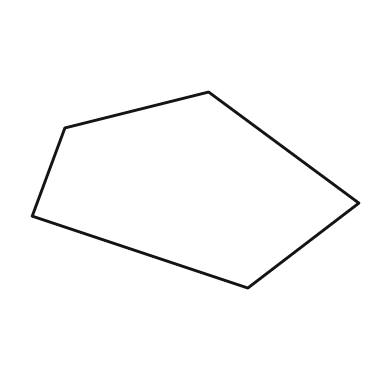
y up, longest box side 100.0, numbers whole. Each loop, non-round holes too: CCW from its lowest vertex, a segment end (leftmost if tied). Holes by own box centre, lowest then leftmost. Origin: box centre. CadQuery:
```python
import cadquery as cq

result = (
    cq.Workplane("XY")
    .moveTo(16.0, -30.0)
    .lineTo(50.0, -4.0)
    .lineTo(4.0, 30.0)
    .lineTo(-40.0, 19.0)
    .lineTo(-50.0, -8.0)
    .close()
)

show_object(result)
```